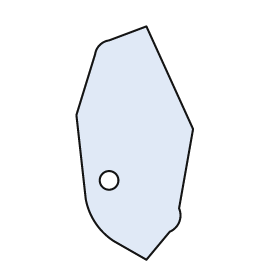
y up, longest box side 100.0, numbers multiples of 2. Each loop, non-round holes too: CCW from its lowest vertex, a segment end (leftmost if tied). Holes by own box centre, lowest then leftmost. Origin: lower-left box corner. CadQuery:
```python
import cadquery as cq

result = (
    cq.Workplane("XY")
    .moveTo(30.0, 0.0)
    .lineTo(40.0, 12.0)
    .threePointArc((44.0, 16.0), (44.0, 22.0))
    .lineTo(50.0, 56.0)
    .lineTo(30.0, 100.0)
    .lineTo(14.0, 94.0)
    .threePointArc((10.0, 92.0), (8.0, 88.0))
    .lineTo(0.0, 62.0)
    .lineTo(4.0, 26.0)
    .threePointArc((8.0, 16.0), (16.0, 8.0))
    .close()
    .moveTo(14.0, 34.0)
    .circle(4.0)
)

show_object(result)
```